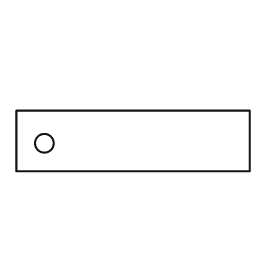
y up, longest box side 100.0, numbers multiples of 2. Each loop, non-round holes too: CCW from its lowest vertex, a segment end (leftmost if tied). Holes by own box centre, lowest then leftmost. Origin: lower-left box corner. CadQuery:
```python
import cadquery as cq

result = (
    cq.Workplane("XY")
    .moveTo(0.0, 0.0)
    .lineTo(100.0, 0.0)
    .lineTo(100.0, 26.0)
    .lineTo(0.0, 26.0)
    .close()
    .moveTo(12.0, 12.0)
    .circle(4.0)
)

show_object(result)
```